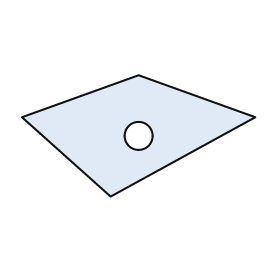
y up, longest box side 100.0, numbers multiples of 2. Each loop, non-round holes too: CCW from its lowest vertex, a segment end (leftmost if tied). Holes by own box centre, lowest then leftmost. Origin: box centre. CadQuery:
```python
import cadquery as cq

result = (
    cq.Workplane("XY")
    .moveTo(-12.0, -26.0)
    .lineTo(50.0, 8.0)
    .lineTo(0.0, 26.0)
    .lineTo(-50.0, 8.0)
    .close()
    .moveTo(0.0, 0.0)
    .circle(6.0)
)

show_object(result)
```